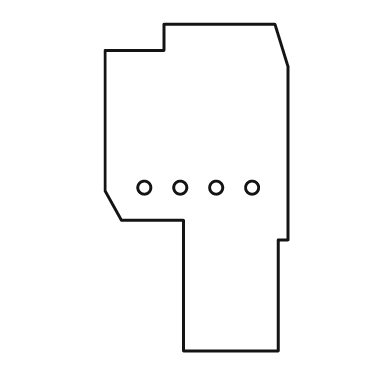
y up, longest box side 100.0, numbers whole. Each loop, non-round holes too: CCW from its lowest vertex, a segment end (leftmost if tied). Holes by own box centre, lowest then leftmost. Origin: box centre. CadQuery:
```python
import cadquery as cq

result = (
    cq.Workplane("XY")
    .moveTo(-4.0, -50.0)
    .lineTo(25.0, -50.0)
    .lineTo(25.0, -16.0)
    .lineTo(28.0, -16.0)
    .lineTo(28.0, 37.0)
    .lineTo(24.0, 50.0)
    .lineTo(-10.0, 50.0)
    .lineTo(-10.0, 42.0)
    .lineTo(-28.0, 42.0)
    .lineTo(-28.0, -1.0)
    .lineTo(-23.0, -10.0)
    .lineTo(-4.0, -10.0)
    .close()
    .moveTo(-16.0, 0.0)
    .circle(2.0)
    .moveTo(-5.0, 0.0)
    .circle(2.0)
    .moveTo(6.0, 0.0)
    .circle(2.0)
    .moveTo(17.0, 0.0)
    .circle(2.0)
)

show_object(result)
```